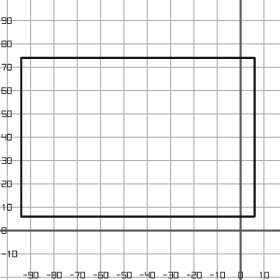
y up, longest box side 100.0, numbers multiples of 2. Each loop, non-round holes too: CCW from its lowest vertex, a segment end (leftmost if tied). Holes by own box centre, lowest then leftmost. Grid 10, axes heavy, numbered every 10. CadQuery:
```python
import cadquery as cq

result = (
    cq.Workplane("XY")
    .moveTo(-94.0, 6.0)
    .lineTo(6.0, 6.0)
    .lineTo(6.0, 74.0)
    .lineTo(-94.0, 74.0)
    .close()
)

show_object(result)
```